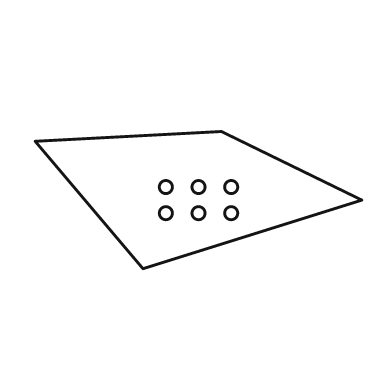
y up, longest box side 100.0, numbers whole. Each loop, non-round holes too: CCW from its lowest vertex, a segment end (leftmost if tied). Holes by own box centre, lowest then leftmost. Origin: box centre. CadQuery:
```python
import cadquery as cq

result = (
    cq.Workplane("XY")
    .moveTo(-17.0, -21.0)
    .lineTo(50.0, 0.0)
    .lineTo(7.0, 21.0)
    .lineTo(-50.0, 18.0)
    .close()
    .moveTo(-10.0, -4.0)
    .circle(2.0)
    .moveTo(0.0, -4.0)
    .circle(2.0)
    .moveTo(10.0, -4.0)
    .circle(2.0)
    .moveTo(-10.0, 4.0)
    .circle(2.0)
    .moveTo(0.0, 4.0)
    .circle(2.0)
    .moveTo(10.0, 4.0)
    .circle(2.0)
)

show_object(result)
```